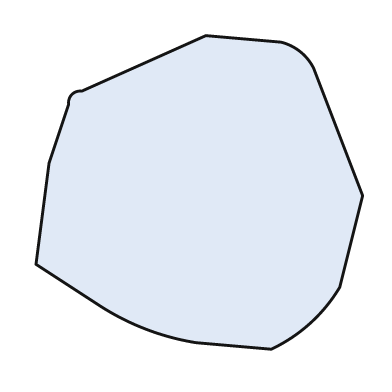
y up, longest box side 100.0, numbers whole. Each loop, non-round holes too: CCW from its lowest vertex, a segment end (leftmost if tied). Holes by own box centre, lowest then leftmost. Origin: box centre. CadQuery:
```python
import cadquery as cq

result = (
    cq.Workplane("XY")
    .moveTo(22.0, -48.0)
    .threePointArc((34.0, -40.0), (43.0, -29.0))
    .lineTo(50.0, -1.0)
    .lineTo(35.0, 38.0)
    .threePointArc((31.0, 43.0), (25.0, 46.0))
    .lineTo(2.0, 48.0)
    .lineTo(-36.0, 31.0)
    .threePointArc((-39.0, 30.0), (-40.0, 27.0))
    .lineTo(-46.0, 9.0)
    .lineTo(-50.0, -22.0)
    .lineTo(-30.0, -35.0)
    .threePointArc((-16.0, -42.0), (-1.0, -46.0))
    .close()
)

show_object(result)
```